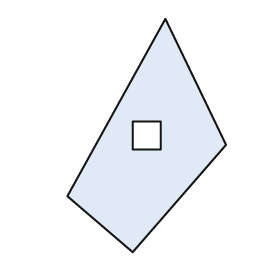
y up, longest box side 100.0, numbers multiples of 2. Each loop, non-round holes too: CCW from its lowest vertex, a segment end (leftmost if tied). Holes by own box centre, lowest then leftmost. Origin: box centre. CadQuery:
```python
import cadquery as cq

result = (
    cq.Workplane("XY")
    .moveTo(-6.0, -50.0)
    .lineTo(34.0, -4.0)
    .lineTo(8.0, 50.0)
    .lineTo(-34.0, -26.0)
    .close()
    .moveTo(-6.0, -6.0)
    .lineTo(6.0, -6.0)
    .lineTo(6.0, 6.0)
    .lineTo(-6.0, 6.0)
    .close()
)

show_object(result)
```